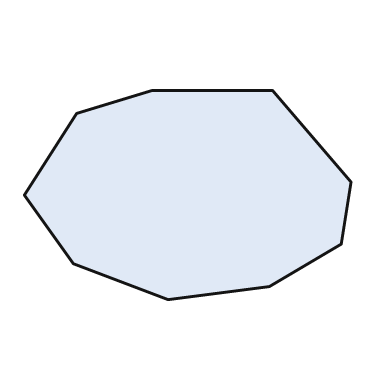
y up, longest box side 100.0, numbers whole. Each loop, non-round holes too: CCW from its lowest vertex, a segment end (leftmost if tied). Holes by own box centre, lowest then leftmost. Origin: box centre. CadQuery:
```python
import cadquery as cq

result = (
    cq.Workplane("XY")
    .moveTo(-6.0, -32.0)
    .lineTo(25.0, -28.0)
    .lineTo(47.0, -15.0)
    .lineTo(50.0, 4.0)
    .lineTo(26.0, 32.0)
    .lineTo(-11.0, 32.0)
    .lineTo(-34.0, 25.0)
    .lineTo(-50.0, 0.0)
    .lineTo(-35.0, -21.0)
    .close()
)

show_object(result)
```